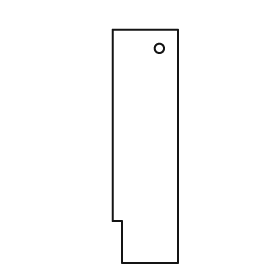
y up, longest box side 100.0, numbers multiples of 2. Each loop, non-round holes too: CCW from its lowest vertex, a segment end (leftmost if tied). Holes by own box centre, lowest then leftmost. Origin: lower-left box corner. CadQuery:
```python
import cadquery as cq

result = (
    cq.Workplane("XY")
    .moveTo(4.0, 0.0)
    .lineTo(28.0, 0.0)
    .lineTo(28.0, 100.0)
    .lineTo(0.0, 100.0)
    .lineTo(0.0, 18.0)
    .lineTo(4.0, 18.0)
    .close()
    .moveTo(20.0, 92.0)
    .circle(2.0)
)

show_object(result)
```